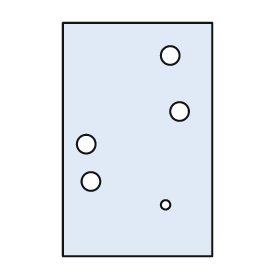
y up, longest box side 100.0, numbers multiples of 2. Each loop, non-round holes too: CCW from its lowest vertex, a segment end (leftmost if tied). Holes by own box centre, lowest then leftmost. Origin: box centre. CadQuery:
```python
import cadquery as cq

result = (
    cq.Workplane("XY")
    .moveTo(-32.0, -50.0)
    .lineTo(32.0, -50.0)
    .lineTo(32.0, 50.0)
    .lineTo(-32.0, 50.0)
    .close()
    .moveTo(12.0, -28.0)
    .circle(2.0)
    .moveTo(-20.0, -18.0)
    .circle(4.0)
    .moveTo(-22.0, -2.0)
    .circle(4.0)
    .moveTo(18.0, 12.0)
    .circle(4.0)
    .moveTo(14.0, 36.0)
    .circle(4.0)
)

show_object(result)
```